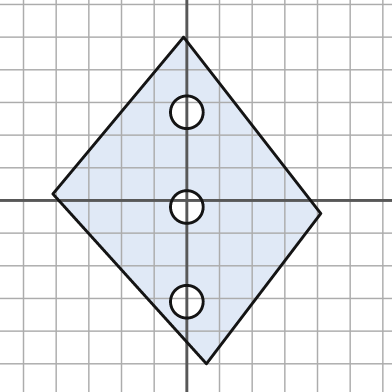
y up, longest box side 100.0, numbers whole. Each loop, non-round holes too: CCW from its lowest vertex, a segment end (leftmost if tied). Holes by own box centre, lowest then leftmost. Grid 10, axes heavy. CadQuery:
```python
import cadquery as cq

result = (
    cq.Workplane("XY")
    .moveTo(6.0, -50.0)
    .lineTo(41.0, -4.0)
    .lineTo(-1.0, 50.0)
    .lineTo(-41.0, 2.0)
    .close()
    .moveTo(0.0, -31.0)
    .circle(5.0)
    .moveTo(0.0, -2.0)
    .circle(5.0)
    .moveTo(0.0, 27.0)
    .circle(5.0)
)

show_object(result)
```